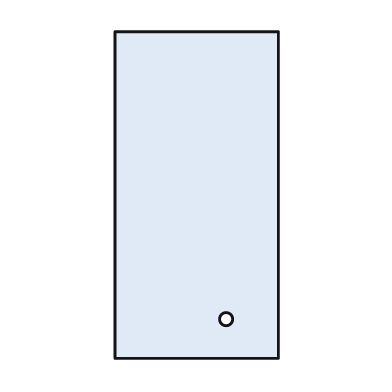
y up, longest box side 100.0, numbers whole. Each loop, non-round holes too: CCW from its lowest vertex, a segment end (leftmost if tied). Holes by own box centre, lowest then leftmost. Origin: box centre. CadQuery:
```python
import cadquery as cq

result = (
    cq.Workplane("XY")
    .moveTo(-25.0, -50.0)
    .lineTo(25.0, -50.0)
    .lineTo(25.0, 50.0)
    .lineTo(-25.0, 50.0)
    .close()
    .moveTo(9.0, -38.0)
    .circle(2.0)
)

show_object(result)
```